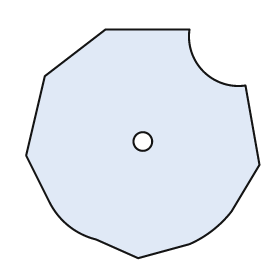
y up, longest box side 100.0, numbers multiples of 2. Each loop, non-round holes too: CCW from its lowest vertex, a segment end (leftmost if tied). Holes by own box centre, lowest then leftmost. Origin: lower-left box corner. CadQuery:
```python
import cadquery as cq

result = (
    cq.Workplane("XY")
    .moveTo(48.0, 0.0)
    .lineTo(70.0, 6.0)
    .threePointArc((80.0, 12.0), (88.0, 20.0))
    .lineTo(100.0, 40.0)
    .lineTo(94.0, 74.0)
    .threePointArc((76.0, 80.0), (70.0, 98.0))
    .lineTo(34.0, 98.0)
    .lineTo(8.0, 78.0)
    .lineTo(0.0, 44.0)
    .lineTo(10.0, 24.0)
    .threePointArc((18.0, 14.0), (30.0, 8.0))
    .close()
    .moveTo(50.0, 50.0)
    .circle(4.0)
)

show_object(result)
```